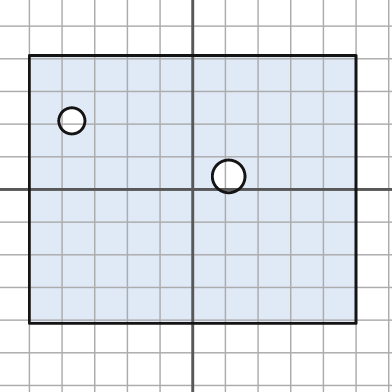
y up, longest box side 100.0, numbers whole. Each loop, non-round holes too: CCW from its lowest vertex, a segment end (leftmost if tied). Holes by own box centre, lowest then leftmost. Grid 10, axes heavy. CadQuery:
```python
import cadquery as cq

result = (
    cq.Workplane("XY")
    .moveTo(-50.0, -41.0)
    .lineTo(50.0, -41.0)
    .lineTo(50.0, 41.0)
    .lineTo(-50.0, 41.0)
    .close()
    .moveTo(11.0, 4.0)
    .circle(5.0)
    .moveTo(-37.0, 21.0)
    .circle(4.0)
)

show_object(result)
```